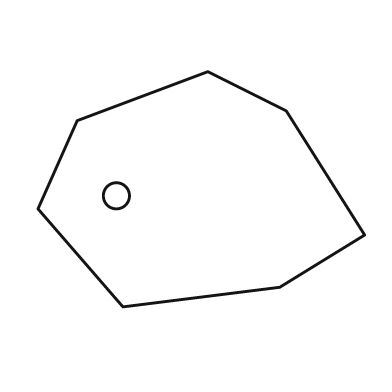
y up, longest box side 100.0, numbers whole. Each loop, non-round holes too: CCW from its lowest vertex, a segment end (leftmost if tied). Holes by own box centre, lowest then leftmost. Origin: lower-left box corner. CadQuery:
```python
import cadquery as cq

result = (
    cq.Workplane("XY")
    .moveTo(26.0, 0.0)
    .lineTo(74.0, 6.0)
    .lineTo(100.0, 22.0)
    .lineTo(76.0, 60.0)
    .lineTo(52.0, 72.0)
    .lineTo(12.0, 57.0)
    .lineTo(0.0, 30.0)
    .close()
    .moveTo(24.0, 34.0)
    .circle(4.0)
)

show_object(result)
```